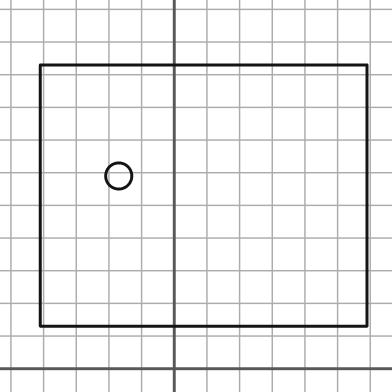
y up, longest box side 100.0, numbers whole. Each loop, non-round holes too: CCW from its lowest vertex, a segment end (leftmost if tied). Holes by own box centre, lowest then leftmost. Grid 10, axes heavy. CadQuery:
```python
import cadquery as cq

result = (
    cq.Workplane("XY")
    .moveTo(-41.0, 13.0)
    .lineTo(59.0, 13.0)
    .lineTo(59.0, 93.0)
    .lineTo(-41.0, 93.0)
    .close()
    .moveTo(-17.0, 59.0)
    .circle(4.0)
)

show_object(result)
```